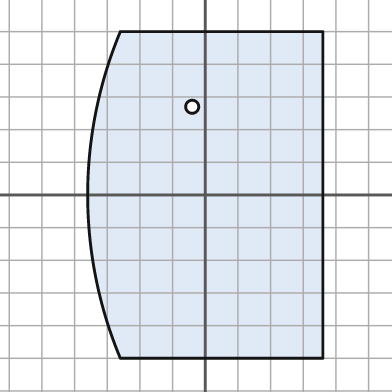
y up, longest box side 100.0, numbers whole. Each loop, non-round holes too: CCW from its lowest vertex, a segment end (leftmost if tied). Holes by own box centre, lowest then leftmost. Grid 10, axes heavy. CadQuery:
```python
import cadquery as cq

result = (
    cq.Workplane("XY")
    .moveTo(-26.0, -50.0)
    .lineTo(36.0, -50.0)
    .lineTo(36.0, 50.0)
    .lineTo(-26.0, 50.0)
    .threePointArc((-36.0, 0.0), (-26.0, -50.0))
    .close()
    .moveTo(-4.0, 27.0)
    .circle(2.0)
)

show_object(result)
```